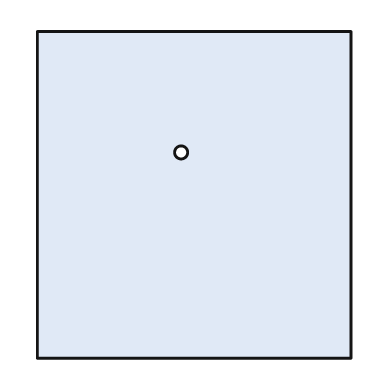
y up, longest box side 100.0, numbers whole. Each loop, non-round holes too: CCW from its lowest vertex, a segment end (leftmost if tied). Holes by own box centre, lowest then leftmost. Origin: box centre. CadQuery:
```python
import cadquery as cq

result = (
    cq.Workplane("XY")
    .moveTo(-48.0, -50.0)
    .lineTo(48.0, -50.0)
    .lineTo(48.0, 50.0)
    .lineTo(-48.0, 50.0)
    .close()
    .moveTo(-4.0, 13.0)
    .circle(2.0)
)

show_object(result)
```